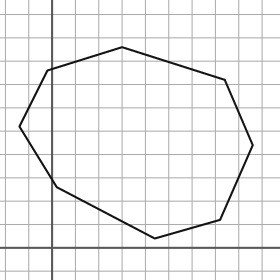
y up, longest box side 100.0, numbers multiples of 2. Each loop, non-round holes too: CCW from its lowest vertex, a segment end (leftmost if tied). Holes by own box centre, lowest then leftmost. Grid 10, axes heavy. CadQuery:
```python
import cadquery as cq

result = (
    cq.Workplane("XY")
    .moveTo(44.0, 4.0)
    .lineTo(72.0, 12.0)
    .lineTo(86.0, 44.0)
    .lineTo(74.0, 72.0)
    .lineTo(30.0, 86.0)
    .lineTo(-2.0, 76.0)
    .lineTo(-14.0, 52.0)
    .lineTo(2.0, 26.0)
    .close()
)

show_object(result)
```